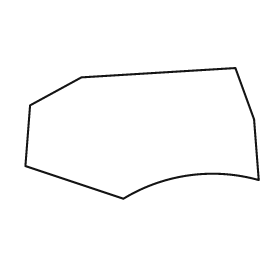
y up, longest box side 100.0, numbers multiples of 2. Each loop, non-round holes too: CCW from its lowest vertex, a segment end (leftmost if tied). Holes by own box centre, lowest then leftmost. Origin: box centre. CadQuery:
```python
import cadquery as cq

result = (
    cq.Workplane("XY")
    .moveTo(-8.0, -28.0)
    .threePointArc((20.0, -18.0), (50.0, -20.0))
    .lineTo(48.0, 6.0)
    .lineTo(40.0, 28.0)
    .lineTo(-26.0, 24.0)
    .lineTo(-48.0, 12.0)
    .lineTo(-50.0, -14.0)
    .close()
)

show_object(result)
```